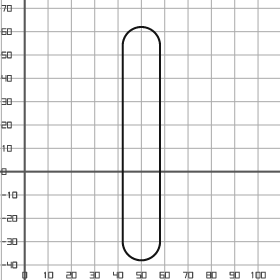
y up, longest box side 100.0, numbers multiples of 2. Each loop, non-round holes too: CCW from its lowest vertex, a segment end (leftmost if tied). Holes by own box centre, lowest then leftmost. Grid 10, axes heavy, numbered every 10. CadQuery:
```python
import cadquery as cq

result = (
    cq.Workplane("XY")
    .moveTo(42.0, -30.0)
    .threePointArc((50.0, -38.0), (58.0, -30.0))
    .lineTo(58.0, 54.0)
    .threePointArc((50.0, 62.0), (42.0, 54.0))
    .close()
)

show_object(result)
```